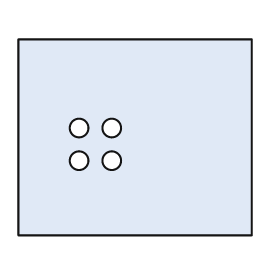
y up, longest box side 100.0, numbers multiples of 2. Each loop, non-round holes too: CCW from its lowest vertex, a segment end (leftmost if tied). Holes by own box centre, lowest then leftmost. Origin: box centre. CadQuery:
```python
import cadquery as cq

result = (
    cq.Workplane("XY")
    .moveTo(-50.0, -42.0)
    .lineTo(50.0, -42.0)
    .lineTo(50.0, 42.0)
    .lineTo(-50.0, 42.0)
    .close()
    .moveTo(-24.0, -10.0)
    .circle(4.0)
    .moveTo(-10.0, -10.0)
    .circle(4.0)
    .moveTo(-24.0, 4.0)
    .circle(4.0)
    .moveTo(-10.0, 4.0)
    .circle(4.0)
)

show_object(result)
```